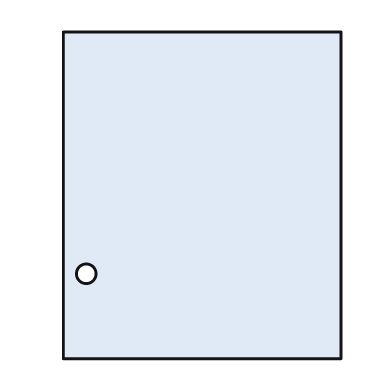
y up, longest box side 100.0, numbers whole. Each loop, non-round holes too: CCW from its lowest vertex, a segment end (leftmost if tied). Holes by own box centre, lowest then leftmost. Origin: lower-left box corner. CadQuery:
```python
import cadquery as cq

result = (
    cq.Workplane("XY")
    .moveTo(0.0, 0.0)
    .lineTo(85.0, 0.0)
    .lineTo(85.0, 100.0)
    .lineTo(0.0, 100.0)
    .close()
    .moveTo(7.0, 26.0)
    .circle(3.0)
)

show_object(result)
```